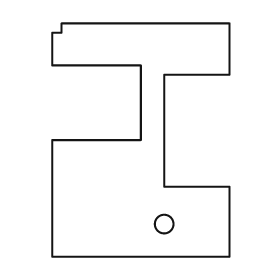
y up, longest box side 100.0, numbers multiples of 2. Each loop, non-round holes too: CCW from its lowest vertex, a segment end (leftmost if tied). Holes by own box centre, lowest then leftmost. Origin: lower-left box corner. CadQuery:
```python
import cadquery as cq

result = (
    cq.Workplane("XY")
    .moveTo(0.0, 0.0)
    .lineTo(76.0, 0.0)
    .lineTo(76.0, 30.0)
    .lineTo(48.0, 30.0)
    .lineTo(48.0, 78.0)
    .lineTo(76.0, 78.0)
    .lineTo(76.0, 100.0)
    .lineTo(4.0, 100.0)
    .lineTo(4.0, 96.0)
    .lineTo(0.0, 96.0)
    .lineTo(0.0, 82.0)
    .lineTo(38.0, 82.0)
    .lineTo(38.0, 50.0)
    .lineTo(0.0, 50.0)
    .close()
    .moveTo(48.0, 14.0)
    .circle(4.0)
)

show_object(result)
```